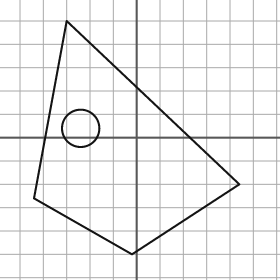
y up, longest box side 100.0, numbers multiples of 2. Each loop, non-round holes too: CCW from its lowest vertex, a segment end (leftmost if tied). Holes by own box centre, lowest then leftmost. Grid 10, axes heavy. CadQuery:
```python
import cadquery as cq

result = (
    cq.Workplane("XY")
    .moveTo(-2.0, -50.0)
    .lineTo(44.0, -20.0)
    .lineTo(-30.0, 50.0)
    .lineTo(-44.0, -26.0)
    .close()
    .moveTo(-24.0, 4.0)
    .circle(8.0)
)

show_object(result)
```